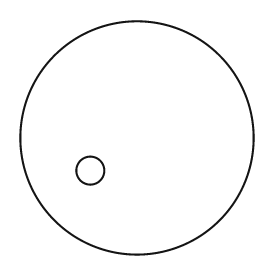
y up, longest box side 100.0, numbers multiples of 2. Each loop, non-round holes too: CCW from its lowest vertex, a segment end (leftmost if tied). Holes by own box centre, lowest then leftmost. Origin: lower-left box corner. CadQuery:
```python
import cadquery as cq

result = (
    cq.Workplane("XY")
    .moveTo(50.0, 50.0)
    .circle(50.0)
    .moveTo(30.0, 36.0)
    .circle(6.0)
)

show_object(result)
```